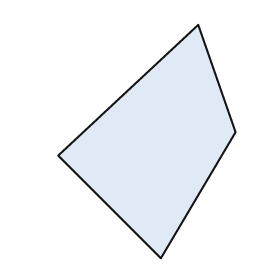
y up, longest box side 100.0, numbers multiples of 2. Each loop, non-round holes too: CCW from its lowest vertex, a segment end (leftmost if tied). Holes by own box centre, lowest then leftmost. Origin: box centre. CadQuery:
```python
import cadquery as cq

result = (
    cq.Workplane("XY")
    .moveTo(6.0, -50.0)
    .lineTo(38.0, 4.0)
    .lineTo(22.0, 50.0)
    .lineTo(-38.0, -6.0)
    .close()
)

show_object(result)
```